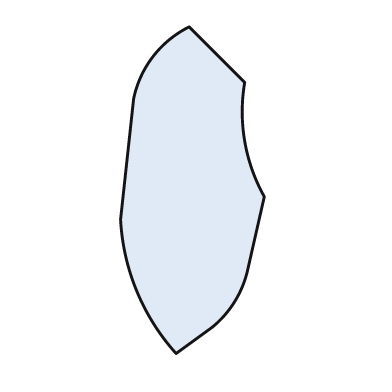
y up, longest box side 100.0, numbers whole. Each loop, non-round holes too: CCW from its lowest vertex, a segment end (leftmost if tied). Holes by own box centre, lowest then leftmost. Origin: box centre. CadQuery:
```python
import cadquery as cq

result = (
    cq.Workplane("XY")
    .moveTo(-5.0, -50.0)
    .lineTo(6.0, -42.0)
    .threePointArc((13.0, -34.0), (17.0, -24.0))
    .lineTo(22.0, -2.0)
    .threePointArc((16.0, 15.0), (16.0, 33.0))
    .lineTo(-1.0, 50.0)
    .threePointArc((-12.0, 41.0), (-18.0, 28.0))
    .lineTo(-22.0, -9.0)
    .threePointArc((-17.0, -31.0), (-5.0, -50.0))
    .close()
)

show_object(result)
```